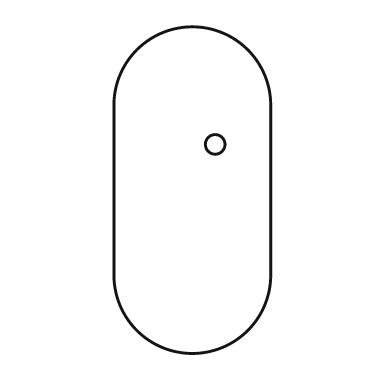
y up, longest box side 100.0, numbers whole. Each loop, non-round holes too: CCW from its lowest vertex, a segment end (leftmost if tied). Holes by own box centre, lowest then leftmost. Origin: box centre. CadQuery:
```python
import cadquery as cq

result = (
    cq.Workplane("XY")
    .moveTo(-24.0, -26.0)
    .threePointArc((0.0, -50.0), (24.0, -26.0))
    .lineTo(24.0, 26.0)
    .threePointArc((0.0, 50.0), (-24.0, 26.0))
    .close()
    .moveTo(7.0, 14.0)
    .circle(3.0)
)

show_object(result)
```